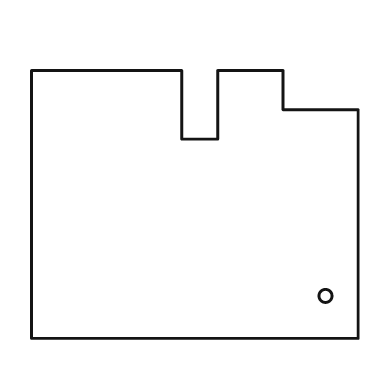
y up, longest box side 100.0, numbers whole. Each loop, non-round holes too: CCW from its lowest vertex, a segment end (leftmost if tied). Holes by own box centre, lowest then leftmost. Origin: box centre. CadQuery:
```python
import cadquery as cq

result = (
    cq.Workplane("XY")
    .moveTo(-50.0, -41.0)
    .lineTo(50.0, -41.0)
    .lineTo(50.0, 29.0)
    .lineTo(27.0, 29.0)
    .lineTo(27.0, 41.0)
    .lineTo(7.0, 41.0)
    .lineTo(7.0, 20.0)
    .lineTo(-4.0, 20.0)
    .lineTo(-4.0, 41.0)
    .lineTo(-50.0, 41.0)
    .close()
    .moveTo(40.0, -28.0)
    .circle(2.0)
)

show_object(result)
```